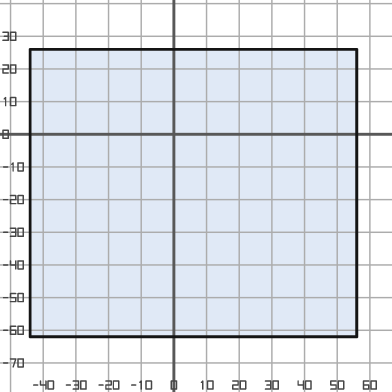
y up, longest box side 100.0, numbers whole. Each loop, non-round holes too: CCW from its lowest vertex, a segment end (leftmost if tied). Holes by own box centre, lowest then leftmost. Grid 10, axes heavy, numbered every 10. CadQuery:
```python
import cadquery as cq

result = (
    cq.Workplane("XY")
    .moveTo(-44.0, -62.0)
    .lineTo(56.0, -62.0)
    .lineTo(56.0, 26.0)
    .lineTo(-44.0, 26.0)
    .close()
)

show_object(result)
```